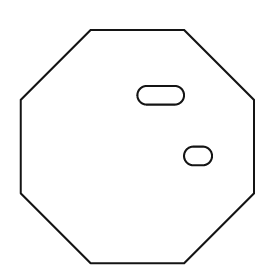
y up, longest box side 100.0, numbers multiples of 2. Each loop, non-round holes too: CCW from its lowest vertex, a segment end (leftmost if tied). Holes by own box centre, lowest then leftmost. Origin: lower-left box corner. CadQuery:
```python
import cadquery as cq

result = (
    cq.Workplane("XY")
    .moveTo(30.0, 0.0)
    .lineTo(70.0, 0.0)
    .lineTo(100.0, 30.0)
    .lineTo(100.0, 70.0)
    .lineTo(70.0, 100.0)
    .lineTo(30.0, 100.0)
    .lineTo(0.0, 70.0)
    .lineTo(0.0, 30.0)
    .close()
    .moveTo(74.0, 42.0)
    .lineTo(78.0, 42.0)
    .threePointArc((82.0, 46.0), (78.0, 50.0))
    .lineTo(74.0, 50.0)
    .threePointArc((70.0, 46.0), (74.0, 42.0))
    .close()
    .moveTo(54.0, 68.0)
    .lineTo(66.0, 68.0)
    .threePointArc((70.0, 72.0), (66.0, 76.0))
    .lineTo(54.0, 76.0)
    .threePointArc((50.0, 72.0), (54.0, 68.0))
    .close()
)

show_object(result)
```